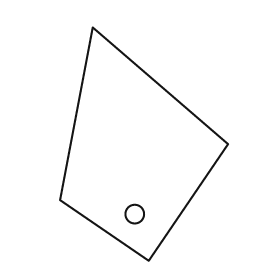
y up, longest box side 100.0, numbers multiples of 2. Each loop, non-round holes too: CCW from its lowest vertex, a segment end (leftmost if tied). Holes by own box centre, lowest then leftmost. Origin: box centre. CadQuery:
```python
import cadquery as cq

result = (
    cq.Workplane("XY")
    .moveTo(2.0, -50.0)
    .lineTo(36.0, 0.0)
    .lineTo(-22.0, 50.0)
    .lineTo(-36.0, -24.0)
    .close()
    .moveTo(-4.0, -30.0)
    .circle(4.0)
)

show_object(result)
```